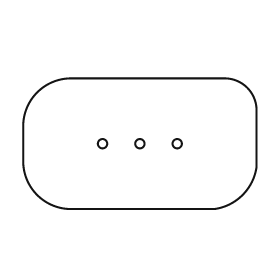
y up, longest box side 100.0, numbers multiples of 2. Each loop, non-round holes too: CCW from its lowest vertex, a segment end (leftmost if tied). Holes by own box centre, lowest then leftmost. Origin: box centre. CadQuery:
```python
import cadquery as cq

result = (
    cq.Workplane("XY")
    .moveTo(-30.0, -28.0)
    .lineTo(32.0, -28.0)
    .threePointArc((44.0, -22.0), (50.0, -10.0))
    .lineTo(50.0, 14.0)
    .threePointArc((46.0, 24.0), (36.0, 28.0))
    .lineTo(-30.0, 28.0)
    .threePointArc((-44.0, 22.0), (-50.0, 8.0))
    .lineTo(-50.0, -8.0)
    .threePointArc((-44.0, -22.0), (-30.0, -28.0))
    .close()
    .moveTo(-16.0, 0.0)
    .circle(2.0)
    .moveTo(0.0, 0.0)
    .circle(2.0)
    .moveTo(16.0, 0.0)
    .circle(2.0)
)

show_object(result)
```